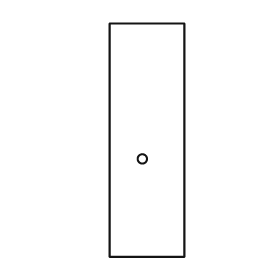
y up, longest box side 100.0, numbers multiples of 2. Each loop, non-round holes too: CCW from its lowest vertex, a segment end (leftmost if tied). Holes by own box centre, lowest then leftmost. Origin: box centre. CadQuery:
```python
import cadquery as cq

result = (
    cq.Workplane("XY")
    .moveTo(-16.0, -50.0)
    .lineTo(16.0, -50.0)
    .lineTo(16.0, 50.0)
    .lineTo(-16.0, 50.0)
    .close()
    .moveTo(-2.0, -8.0)
    .circle(2.0)
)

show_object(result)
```